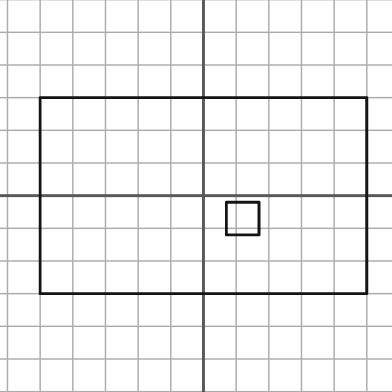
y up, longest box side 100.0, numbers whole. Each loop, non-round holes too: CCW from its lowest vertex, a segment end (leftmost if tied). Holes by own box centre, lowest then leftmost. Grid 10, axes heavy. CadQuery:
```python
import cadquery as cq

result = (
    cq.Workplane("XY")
    .moveTo(-50.0, -30.0)
    .lineTo(50.0, -30.0)
    .lineTo(50.0, 30.0)
    .lineTo(-50.0, 30.0)
    .close()
    .moveTo(7.0, -12.0)
    .lineTo(17.0, -12.0)
    .lineTo(17.0, -2.0)
    .lineTo(7.0, -2.0)
    .close()
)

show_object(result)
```